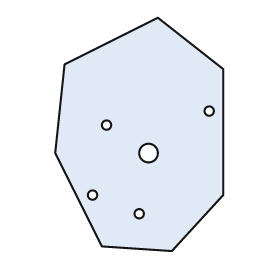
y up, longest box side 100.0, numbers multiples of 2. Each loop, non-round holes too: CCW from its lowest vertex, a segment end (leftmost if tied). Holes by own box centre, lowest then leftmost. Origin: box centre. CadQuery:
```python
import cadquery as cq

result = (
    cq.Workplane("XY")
    .moveTo(14.0, -50.0)
    .lineTo(36.0, -26.0)
    .lineTo(36.0, 28.0)
    .lineTo(8.0, 50.0)
    .lineTo(-32.0, 30.0)
    .lineTo(-36.0, -8.0)
    .lineTo(-16.0, -48.0)
    .close()
    .moveTo(0.0, -34.0)
    .circle(2.0)
    .moveTo(-20.0, -26.0)
    .circle(2.0)
    .moveTo(4.0, -8.0)
    .circle(4.0)
    .moveTo(-14.0, 4.0)
    .circle(2.0)
    .moveTo(30.0, 10.0)
    .circle(2.0)
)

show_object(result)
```